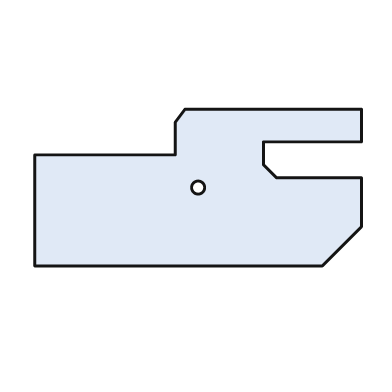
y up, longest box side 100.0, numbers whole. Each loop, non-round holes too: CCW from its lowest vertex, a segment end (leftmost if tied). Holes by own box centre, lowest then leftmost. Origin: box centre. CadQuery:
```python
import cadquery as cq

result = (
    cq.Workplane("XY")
    .moveTo(-50.0, -24.0)
    .lineTo(38.0, -24.0)
    .lineTo(50.0, -12.0)
    .lineTo(50.0, 3.0)
    .lineTo(24.0, 3.0)
    .lineTo(20.0, 7.0)
    .lineTo(20.0, 14.0)
    .lineTo(50.0, 14.0)
    .lineTo(50.0, 24.0)
    .lineTo(-4.0, 24.0)
    .lineTo(-7.0, 20.0)
    .lineTo(-7.0, 10.0)
    .lineTo(-50.0, 10.0)
    .close()
    .moveTo(0.0, 0.0)
    .circle(2.0)
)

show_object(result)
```